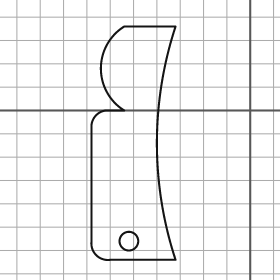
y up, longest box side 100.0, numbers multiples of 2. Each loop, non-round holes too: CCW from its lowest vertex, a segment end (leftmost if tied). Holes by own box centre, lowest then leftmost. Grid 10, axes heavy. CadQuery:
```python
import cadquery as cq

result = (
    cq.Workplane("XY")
    .moveTo(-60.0, -64.0)
    .lineTo(-32.0, -64.0)
    .threePointArc((-40.0, -14.0), (-32.0, 36.0))
    .lineTo(-54.0, 36.0)
    .threePointArc((-64.0, 18.0), (-54.0, 0.0))
    .lineTo(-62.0, 0.0)
    .threePointArc((-66.0, -2.0), (-68.0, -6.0))
    .lineTo(-68.0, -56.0)
    .threePointArc((-66.0, -62.0), (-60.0, -64.0))
    .close()
    .moveTo(-52.0, -56.0)
    .circle(4.0)
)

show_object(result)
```